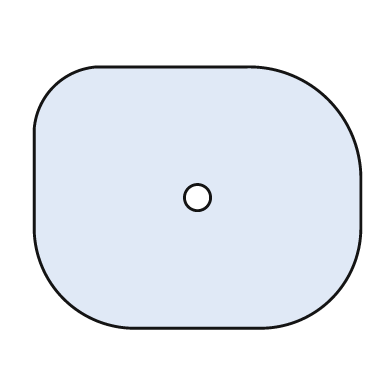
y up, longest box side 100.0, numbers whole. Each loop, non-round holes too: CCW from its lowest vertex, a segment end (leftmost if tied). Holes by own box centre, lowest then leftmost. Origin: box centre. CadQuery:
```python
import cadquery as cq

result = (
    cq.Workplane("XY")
    .moveTo(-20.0, -40.0)
    .lineTo(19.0, -40.0)
    .threePointArc((41.0, -31.0), (50.0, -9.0))
    .lineTo(50.0, 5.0)
    .threePointArc((40.0, 30.0), (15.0, 40.0))
    .lineTo(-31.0, 40.0)
    .threePointArc((-44.0, 34.0), (-50.0, 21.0))
    .lineTo(-50.0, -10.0)
    .threePointArc((-41.0, -31.0), (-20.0, -40.0))
    .close()
    .moveTo(0.0, 0.0)
    .circle(4.0)
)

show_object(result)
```